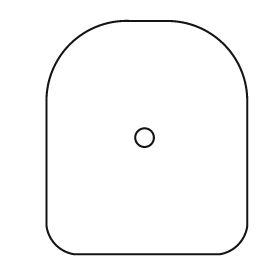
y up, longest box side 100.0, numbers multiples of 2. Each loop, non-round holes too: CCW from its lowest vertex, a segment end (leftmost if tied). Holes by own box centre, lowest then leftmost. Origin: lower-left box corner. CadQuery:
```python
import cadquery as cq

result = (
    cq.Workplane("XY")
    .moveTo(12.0, 0.0)
    .lineTo(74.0, 0.0)
    .threePointArc((82.0, 4.0), (86.0, 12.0))
    .lineTo(86.0, 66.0)
    .threePointArc((76.0, 90.0), (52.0, 100.0))
    .lineTo(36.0, 100.0)
    .threePointArc((10.0, 90.0), (0.0, 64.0))
    .lineTo(0.0, 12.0)
    .threePointArc((4.0, 4.0), (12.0, 0.0))
    .close()
    .moveTo(42.0, 50.0)
    .circle(4.0)
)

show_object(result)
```